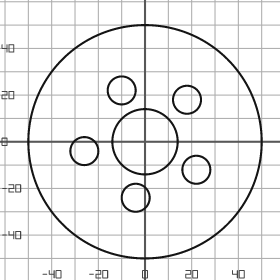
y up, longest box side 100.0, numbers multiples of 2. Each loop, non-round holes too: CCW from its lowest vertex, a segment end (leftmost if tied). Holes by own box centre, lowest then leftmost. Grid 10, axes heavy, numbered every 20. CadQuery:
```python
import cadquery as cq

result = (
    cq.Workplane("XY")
    .moveTo(0.0, 0.0)
    .circle(50.0)
    .moveTo(-4.0, -24.0)
    .circle(6.0)
    .moveTo(22.0, -12.0)
    .circle(6.0)
    .moveTo(-26.0, -4.0)
    .circle(6.0)
    .moveTo(0.0, 0.0)
    .circle(14.0)
    .moveTo(18.0, 18.0)
    .circle(6.0)
    .moveTo(-10.0, 22.0)
    .circle(6.0)
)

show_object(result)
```